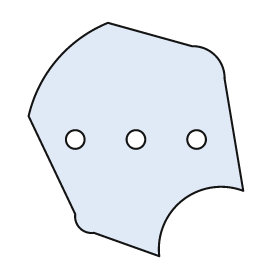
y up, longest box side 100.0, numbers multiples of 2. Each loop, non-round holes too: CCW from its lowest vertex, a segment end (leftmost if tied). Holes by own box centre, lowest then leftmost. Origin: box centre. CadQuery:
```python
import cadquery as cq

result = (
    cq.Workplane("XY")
    .moveTo(10.0, -50.0)
    .threePointArc((20.0, -26.0), (46.0, -22.0))
    .lineTo(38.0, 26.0)
    .threePointArc((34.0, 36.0), (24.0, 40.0))
    .lineTo(-12.0, 50.0)
    .threePointArc((-34.0, 34.0), (-46.0, 10.0))
    .lineTo(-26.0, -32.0)
    .threePointArc((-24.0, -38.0), (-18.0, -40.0))
    .close()
    .moveTo(-26.0, 0.0)
    .circle(4.0)
    .moveTo(0.0, 0.0)
    .circle(4.0)
    .moveTo(26.0, 0.0)
    .circle(4.0)
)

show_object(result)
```